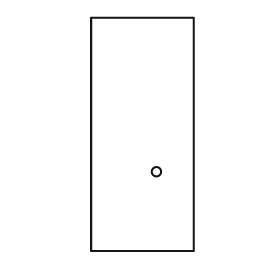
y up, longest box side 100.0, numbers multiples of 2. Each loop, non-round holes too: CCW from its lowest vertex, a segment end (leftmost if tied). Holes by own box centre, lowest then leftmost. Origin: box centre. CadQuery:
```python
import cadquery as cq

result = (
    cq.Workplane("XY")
    .moveTo(-22.0, -50.0)
    .lineTo(22.0, -50.0)
    .lineTo(22.0, 50.0)
    .lineTo(-22.0, 50.0)
    .close()
    .moveTo(6.0, -16.0)
    .circle(2.0)
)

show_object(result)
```